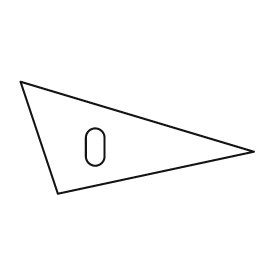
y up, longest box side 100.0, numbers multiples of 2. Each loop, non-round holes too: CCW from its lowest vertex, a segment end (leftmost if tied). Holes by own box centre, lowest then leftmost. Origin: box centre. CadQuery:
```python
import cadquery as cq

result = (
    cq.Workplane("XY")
    .moveTo(-34.0, -24.0)
    .lineTo(50.0, -6.0)
    .lineTo(-50.0, 24.0)
    .close()
    .moveTo(-22.0, -8.0)
    .threePointArc((-18.0, -12.0), (-14.0, -8.0))
    .lineTo(-14.0, 0.0)
    .threePointArc((-18.0, 4.0), (-22.0, 0.0))
    .close()
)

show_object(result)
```